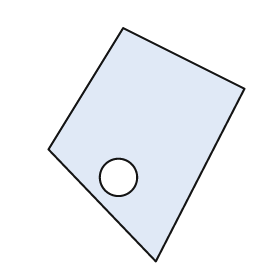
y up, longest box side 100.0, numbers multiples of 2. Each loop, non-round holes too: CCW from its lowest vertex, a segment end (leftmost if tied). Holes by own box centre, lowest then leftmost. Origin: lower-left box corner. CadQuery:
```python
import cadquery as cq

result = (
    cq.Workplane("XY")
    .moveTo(46.0, 0.0)
    .lineTo(84.0, 74.0)
    .lineTo(32.0, 100.0)
    .lineTo(0.0, 48.0)
    .close()
    .moveTo(30.0, 36.0)
    .circle(8.0)
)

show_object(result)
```